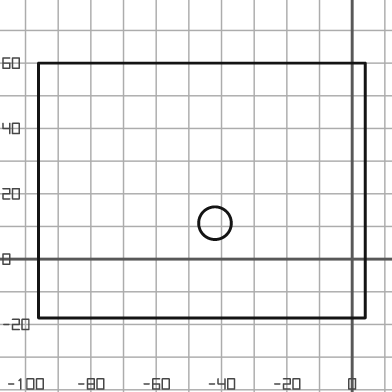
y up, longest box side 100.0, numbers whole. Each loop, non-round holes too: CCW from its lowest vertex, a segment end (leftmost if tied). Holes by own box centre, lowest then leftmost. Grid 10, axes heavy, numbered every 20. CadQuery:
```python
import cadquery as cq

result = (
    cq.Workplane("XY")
    .moveTo(-96.0, -18.0)
    .lineTo(4.0, -18.0)
    .lineTo(4.0, 60.0)
    .lineTo(-96.0, 60.0)
    .close()
    .moveTo(-42.0, 11.0)
    .circle(5.0)
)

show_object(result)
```